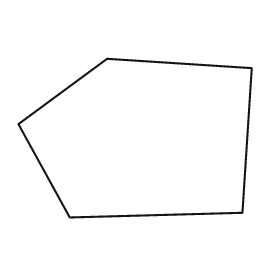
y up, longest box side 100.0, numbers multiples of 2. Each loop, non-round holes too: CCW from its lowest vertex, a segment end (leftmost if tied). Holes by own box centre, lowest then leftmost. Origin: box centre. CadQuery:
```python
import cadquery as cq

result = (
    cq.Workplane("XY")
    .moveTo(-28.0, -34.0)
    .lineTo(46.0, -32.0)
    .lineTo(50.0, 30.0)
    .lineTo(-12.0, 34.0)
    .lineTo(-50.0, 6.0)
    .close()
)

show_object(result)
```